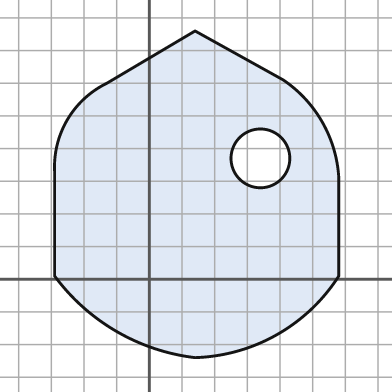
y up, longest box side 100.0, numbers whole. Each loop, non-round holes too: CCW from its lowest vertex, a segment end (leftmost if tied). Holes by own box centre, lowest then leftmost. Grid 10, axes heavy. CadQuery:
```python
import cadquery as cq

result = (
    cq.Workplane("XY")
    .moveTo(14.0, -24.0)
    .threePointArc((39.0, -17.0), (58.0, 1.0))
    .lineTo(58.0, 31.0)
    .threePointArc((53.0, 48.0), (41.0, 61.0))
    .lineTo(14.0, 76.0)
    .lineTo(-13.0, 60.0)
    .threePointArc((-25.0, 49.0), (-29.0, 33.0))
    .lineTo(-29.0, 1.0)
    .threePointArc((-10.0, -16.0), (14.0, -24.0))
    .close()
    .moveTo(34.0, 37.0)
    .circle(9.0)
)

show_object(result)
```